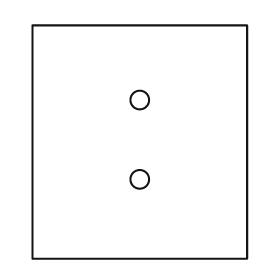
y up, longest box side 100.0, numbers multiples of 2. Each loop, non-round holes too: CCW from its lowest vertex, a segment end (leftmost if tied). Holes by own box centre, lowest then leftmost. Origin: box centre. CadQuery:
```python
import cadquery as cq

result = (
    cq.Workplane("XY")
    .moveTo(-46.0, -50.0)
    .lineTo(46.0, -50.0)
    .lineTo(46.0, 50.0)
    .lineTo(-46.0, 50.0)
    .close()
    .moveTo(0.0, -16.0)
    .circle(4.0)
    .moveTo(0.0, 18.0)
    .circle(4.0)
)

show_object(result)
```